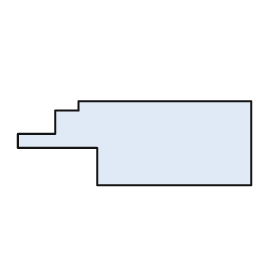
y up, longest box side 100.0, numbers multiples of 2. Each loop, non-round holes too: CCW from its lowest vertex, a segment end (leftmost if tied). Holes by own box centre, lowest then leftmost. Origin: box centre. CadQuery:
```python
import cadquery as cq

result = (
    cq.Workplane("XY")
    .moveTo(-16.0, -18.0)
    .lineTo(50.0, -18.0)
    .lineTo(50.0, 18.0)
    .lineTo(-24.0, 18.0)
    .lineTo(-24.0, 14.0)
    .lineTo(-34.0, 14.0)
    .lineTo(-34.0, 4.0)
    .lineTo(-50.0, 4.0)
    .lineTo(-50.0, -2.0)
    .lineTo(-16.0, -2.0)
    .close()
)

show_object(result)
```